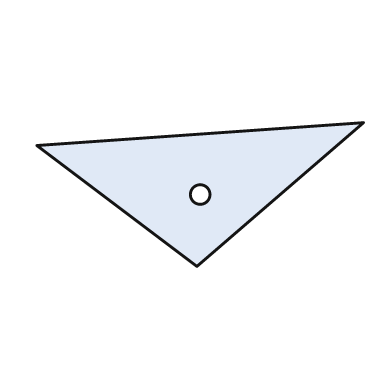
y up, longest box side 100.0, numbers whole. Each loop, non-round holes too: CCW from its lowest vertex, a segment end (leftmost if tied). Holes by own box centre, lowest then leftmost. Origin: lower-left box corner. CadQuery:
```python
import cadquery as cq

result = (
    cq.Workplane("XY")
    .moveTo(49.0, 0.0)
    .lineTo(100.0, 44.0)
    .lineTo(0.0, 37.0)
    .close()
    .moveTo(50.0, 22.0)
    .circle(3.0)
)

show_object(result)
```